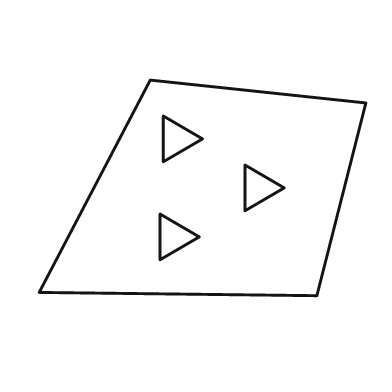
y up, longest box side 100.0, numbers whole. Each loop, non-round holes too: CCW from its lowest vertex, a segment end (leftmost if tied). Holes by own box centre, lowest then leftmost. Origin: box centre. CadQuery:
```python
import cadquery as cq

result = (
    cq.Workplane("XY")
    .moveTo(35.0, -33.0)
    .lineTo(50.0, 26.0)
    .lineTo(-16.0, 33.0)
    .lineTo(-50.0, -32.0)
    .close()
    .moveTo(-13.0, -22.0)
    .lineTo(-1.0, -15.0)
    .lineTo(-13.0, -8.0)
    .close()
    .moveTo(13.0, -7.0)
    .lineTo(25.0, 0.0)
    .lineTo(13.0, 7.0)
    .close()
    .moveTo(-12.0, 8.0)
    .lineTo(0.0, 15.0)
    .lineTo(-12.0, 22.0)
    .close()
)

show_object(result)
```